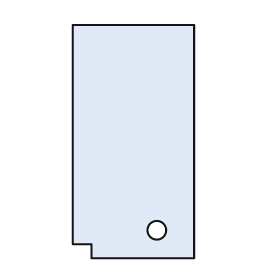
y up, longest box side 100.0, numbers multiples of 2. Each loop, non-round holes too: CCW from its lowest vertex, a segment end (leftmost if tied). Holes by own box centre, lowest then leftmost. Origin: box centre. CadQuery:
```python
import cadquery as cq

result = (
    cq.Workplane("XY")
    .moveTo(-18.0, -50.0)
    .lineTo(26.0, -50.0)
    .lineTo(26.0, 50.0)
    .lineTo(-26.0, 50.0)
    .lineTo(-26.0, -44.0)
    .lineTo(-18.0, -44.0)
    .close()
    .moveTo(10.0, -38.0)
    .circle(4.0)
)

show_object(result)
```